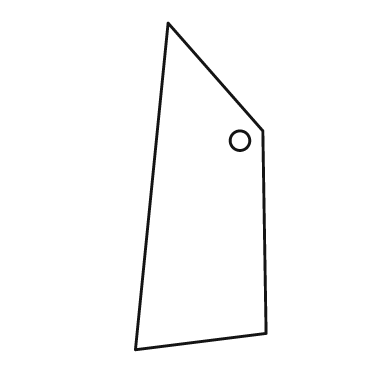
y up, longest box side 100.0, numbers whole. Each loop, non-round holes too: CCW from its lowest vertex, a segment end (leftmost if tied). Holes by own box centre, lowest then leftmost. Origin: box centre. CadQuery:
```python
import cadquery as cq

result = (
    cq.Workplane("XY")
    .moveTo(-20.0, -50.0)
    .lineTo(20.0, -45.0)
    .lineTo(19.0, 17.0)
    .lineTo(-10.0, 50.0)
    .close()
    .moveTo(12.0, 14.0)
    .circle(3.0)
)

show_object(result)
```